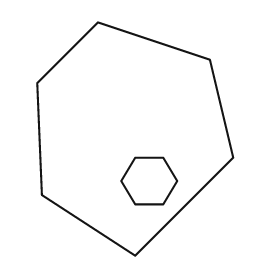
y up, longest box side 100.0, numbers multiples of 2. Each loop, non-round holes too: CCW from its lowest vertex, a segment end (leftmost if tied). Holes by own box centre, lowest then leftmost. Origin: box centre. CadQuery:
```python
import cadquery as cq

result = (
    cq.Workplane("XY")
    .moveTo(0.0, -50.0)
    .lineTo(42.0, -8.0)
    .lineTo(32.0, 34.0)
    .lineTo(-16.0, 50.0)
    .lineTo(-42.0, 24.0)
    .lineTo(-40.0, -24.0)
    .close()
    .moveTo(0.0, -28.0)
    .lineTo(12.0, -28.0)
    .lineTo(18.0, -18.0)
    .lineTo(12.0, -8.0)
    .lineTo(0.0, -8.0)
    .lineTo(-6.0, -18.0)
    .close()
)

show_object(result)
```